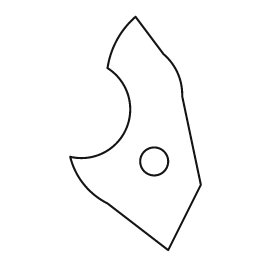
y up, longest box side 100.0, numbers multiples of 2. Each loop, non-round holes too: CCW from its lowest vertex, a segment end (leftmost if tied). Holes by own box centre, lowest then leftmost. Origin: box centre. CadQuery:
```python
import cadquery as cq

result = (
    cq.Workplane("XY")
    .moveTo(14.0, -50.0)
    .lineTo(28.0, -22.0)
    .lineTo(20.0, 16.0)
    .threePointArc((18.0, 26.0), (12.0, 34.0))
    .lineTo(0.0, 50.0)
    .threePointArc((-8.0, 40.0), (-12.0, 28.0))
    .threePointArc((-4.0, 2.0), (-28.0, -10.0))
    .threePointArc((-22.0, -22.0), (-12.0, -30.0))
    .close()
    .moveTo(8.0, -12.0)
    .circle(6.0)
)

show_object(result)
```